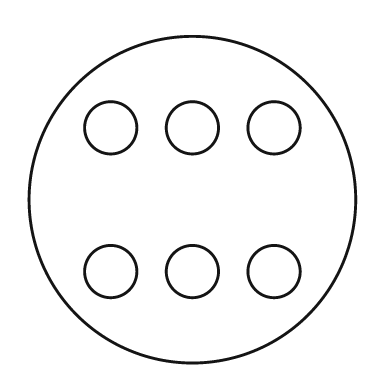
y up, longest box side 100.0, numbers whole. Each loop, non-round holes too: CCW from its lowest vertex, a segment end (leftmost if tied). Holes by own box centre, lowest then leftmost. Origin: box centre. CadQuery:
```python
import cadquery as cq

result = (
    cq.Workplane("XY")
    .moveTo(0.0, 0.0)
    .circle(50.0)
    .moveTo(-25.0, -22.0)
    .circle(8.0)
    .moveTo(0.0, -22.0)
    .circle(8.0)
    .moveTo(25.0, -22.0)
    .circle(8.0)
    .moveTo(-25.0, 22.0)
    .circle(8.0)
    .moveTo(0.0, 22.0)
    .circle(8.0)
    .moveTo(25.0, 22.0)
    .circle(8.0)
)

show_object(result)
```